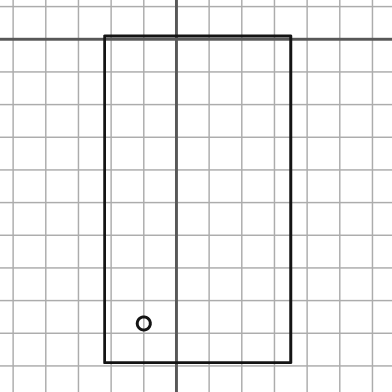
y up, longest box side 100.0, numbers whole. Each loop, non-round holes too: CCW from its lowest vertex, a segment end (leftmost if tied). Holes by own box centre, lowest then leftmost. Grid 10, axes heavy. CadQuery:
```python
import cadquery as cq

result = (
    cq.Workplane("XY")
    .moveTo(-22.0, -99.0)
    .lineTo(35.0, -99.0)
    .lineTo(35.0, 1.0)
    .lineTo(-22.0, 1.0)
    .close()
    .moveTo(-10.0, -87.0)
    .circle(2.0)
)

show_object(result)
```